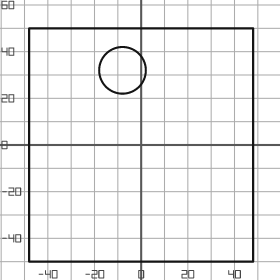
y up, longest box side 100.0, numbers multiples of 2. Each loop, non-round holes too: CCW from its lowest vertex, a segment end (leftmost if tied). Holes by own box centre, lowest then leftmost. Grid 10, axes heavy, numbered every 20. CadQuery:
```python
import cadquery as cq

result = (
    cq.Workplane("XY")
    .moveTo(-48.0, -50.0)
    .lineTo(48.0, -50.0)
    .lineTo(48.0, 50.0)
    .lineTo(-48.0, 50.0)
    .close()
    .moveTo(-8.0, 32.0)
    .circle(10.0)
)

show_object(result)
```